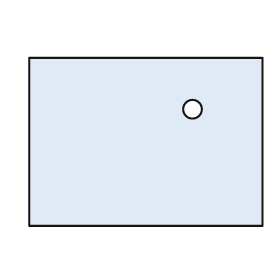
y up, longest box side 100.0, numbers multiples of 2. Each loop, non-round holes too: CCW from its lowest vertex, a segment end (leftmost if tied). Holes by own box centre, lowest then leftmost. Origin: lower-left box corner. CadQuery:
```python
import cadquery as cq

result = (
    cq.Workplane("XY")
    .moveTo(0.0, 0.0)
    .lineTo(100.0, 0.0)
    .lineTo(100.0, 72.0)
    .lineTo(0.0, 72.0)
    .close()
    .moveTo(70.0, 50.0)
    .circle(4.0)
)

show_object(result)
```